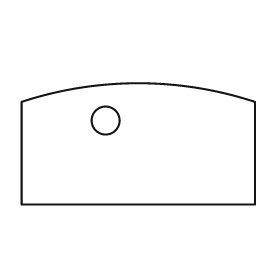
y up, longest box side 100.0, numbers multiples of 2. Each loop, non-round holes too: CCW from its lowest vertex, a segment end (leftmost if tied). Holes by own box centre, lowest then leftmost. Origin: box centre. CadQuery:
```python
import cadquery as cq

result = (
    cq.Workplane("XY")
    .moveTo(-50.0, -26.0)
    .lineTo(50.0, -26.0)
    .lineTo(50.0, 18.0)
    .threePointArc((0.0, 26.0), (-50.0, 18.0))
    .close()
    .moveTo(-14.0, 10.0)
    .circle(6.0)
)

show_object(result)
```